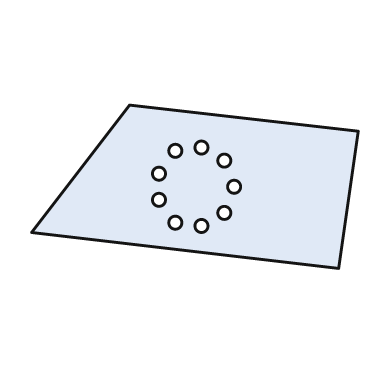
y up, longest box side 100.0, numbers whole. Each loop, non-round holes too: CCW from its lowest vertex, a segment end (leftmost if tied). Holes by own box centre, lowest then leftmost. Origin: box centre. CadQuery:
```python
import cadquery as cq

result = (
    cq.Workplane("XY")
    .moveTo(44.0, -25.0)
    .lineTo(50.0, 17.0)
    .lineTo(-20.0, 25.0)
    .lineTo(-50.0, -14.0)
    .close()
    .moveTo(2.0, -12.0)
    .circle(2.0)
    .moveTo(-6.0, -11.0)
    .circle(2.0)
    .moveTo(9.0, -8.0)
    .circle(2.0)
    .moveTo(-11.0, -4.0)
    .circle(2.0)
    .moveTo(12.0, 0.0)
    .circle(2.0)
    .moveTo(-11.0, 4.0)
    .circle(2.0)
    .moveTo(9.0, 8.0)
    .circle(2.0)
    .moveTo(-6.0, 11.0)
    .circle(2.0)
    .moveTo(2.0, 12.0)
    .circle(2.0)
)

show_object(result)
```